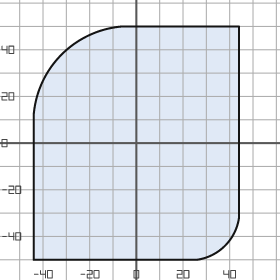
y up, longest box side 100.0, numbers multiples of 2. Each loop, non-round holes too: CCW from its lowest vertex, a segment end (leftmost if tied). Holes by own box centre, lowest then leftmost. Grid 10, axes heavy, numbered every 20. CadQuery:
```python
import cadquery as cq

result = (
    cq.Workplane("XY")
    .moveTo(-44.0, -50.0)
    .lineTo(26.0, -50.0)
    .threePointArc((38.0, -44.0), (44.0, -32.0))
    .lineTo(44.0, 50.0)
    .lineTo(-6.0, 50.0)
    .threePointArc((-32.0, 38.0), (-44.0, 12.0))
    .close()
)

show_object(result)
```